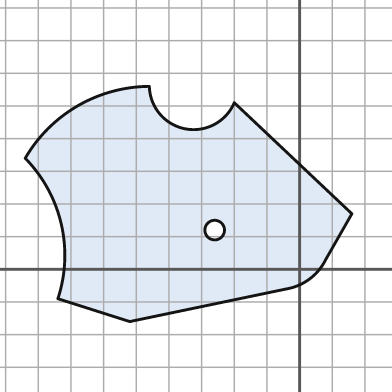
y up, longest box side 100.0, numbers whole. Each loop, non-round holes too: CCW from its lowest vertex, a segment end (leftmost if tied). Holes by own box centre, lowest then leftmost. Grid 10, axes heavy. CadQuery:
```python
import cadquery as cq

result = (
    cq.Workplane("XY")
    .moveTo(-52.0, -16.0)
    .lineTo(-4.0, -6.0)
    .threePointArc((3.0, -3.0), (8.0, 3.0))
    .lineTo(16.0, 17.0)
    .lineTo(-20.0, 51.0)
    .threePointArc((-35.0, 43.0), (-46.0, 56.0))
    .threePointArc((-68.0, 50.0), (-84.0, 34.0))
    .threePointArc((-73.0, 14.0), (-74.0, -9.0))
    .close()
    .moveTo(-26.0, 12.0)
    .circle(3.0)
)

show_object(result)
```